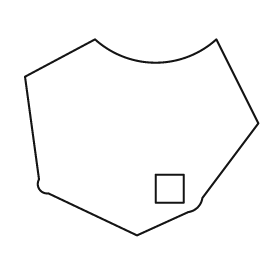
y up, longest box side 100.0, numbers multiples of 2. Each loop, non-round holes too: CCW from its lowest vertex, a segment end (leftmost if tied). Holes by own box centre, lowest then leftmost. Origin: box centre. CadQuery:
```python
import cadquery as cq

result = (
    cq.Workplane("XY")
    .moveTo(-2.0, -42.0)
    .lineTo(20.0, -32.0)
    .threePointArc((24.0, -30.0), (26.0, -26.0))
    .lineTo(50.0, 6.0)
    .lineTo(32.0, 42.0)
    .threePointArc((6.0, 32.0), (-20.0, 42.0))
    .lineTo(-50.0, 26.0)
    .lineTo(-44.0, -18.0)
    .threePointArc((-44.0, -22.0), (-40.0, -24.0))
    .close()
    .moveTo(6.0, -28.0)
    .lineTo(18.0, -28.0)
    .lineTo(18.0, -16.0)
    .lineTo(6.0, -16.0)
    .close()
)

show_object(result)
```